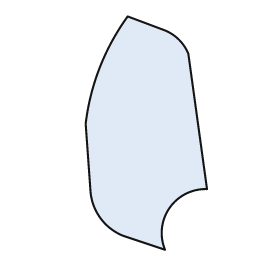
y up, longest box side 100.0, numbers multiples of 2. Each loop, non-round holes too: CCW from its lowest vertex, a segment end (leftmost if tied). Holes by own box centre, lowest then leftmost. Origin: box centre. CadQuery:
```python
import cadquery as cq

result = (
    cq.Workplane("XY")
    .moveTo(8.0, -50.0)
    .threePointArc((10.0, -32.0), (26.0, -24.0))
    .lineTo(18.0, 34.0)
    .threePointArc((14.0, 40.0), (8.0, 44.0))
    .lineTo(-8.0, 50.0)
    .threePointArc((-20.0, 28.0), (-26.0, 4.0))
    .lineTo(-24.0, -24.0)
    .threePointArc((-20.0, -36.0), (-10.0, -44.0))
    .close()
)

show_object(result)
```